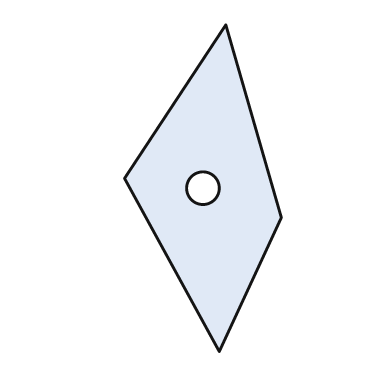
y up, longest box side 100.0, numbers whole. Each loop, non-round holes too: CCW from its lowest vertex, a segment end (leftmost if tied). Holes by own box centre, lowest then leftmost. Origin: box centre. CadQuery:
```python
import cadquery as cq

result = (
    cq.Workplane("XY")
    .moveTo(5.0, -50.0)
    .lineTo(24.0, -9.0)
    .lineTo(7.0, 50.0)
    .lineTo(-24.0, 3.0)
    .close()
    .moveTo(0.0, 0.0)
    .circle(5.0)
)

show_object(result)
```